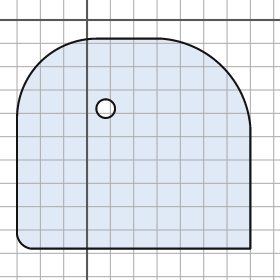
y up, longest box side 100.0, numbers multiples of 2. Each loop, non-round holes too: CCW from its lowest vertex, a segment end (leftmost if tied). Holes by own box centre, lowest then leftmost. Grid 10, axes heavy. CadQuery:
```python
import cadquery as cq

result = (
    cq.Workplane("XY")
    .moveTo(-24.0, -98.0)
    .lineTo(70.0, -98.0)
    .lineTo(70.0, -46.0)
    .threePointArc((58.0, -20.0), (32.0, -8.0))
    .lineTo(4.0, -8.0)
    .threePointArc((-20.0, -18.0), (-30.0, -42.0))
    .lineTo(-30.0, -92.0)
    .threePointArc((-28.0, -96.0), (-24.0, -98.0))
    .close()
    .moveTo(8.0, -38.0)
    .circle(4.0)
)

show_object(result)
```